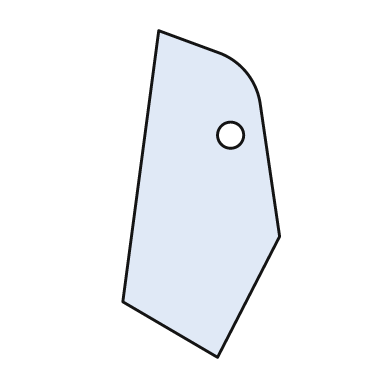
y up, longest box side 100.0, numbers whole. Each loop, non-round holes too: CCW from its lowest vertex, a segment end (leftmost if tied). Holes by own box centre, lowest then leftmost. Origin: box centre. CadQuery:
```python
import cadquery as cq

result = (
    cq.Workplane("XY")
    .moveTo(5.0, -50.0)
    .lineTo(24.0, -13.0)
    .lineTo(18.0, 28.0)
    .threePointArc((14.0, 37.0), (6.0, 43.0))
    .lineTo(-13.0, 50.0)
    .lineTo(-24.0, -33.0)
    .close()
    .moveTo(9.0, 18.0)
    .circle(4.0)
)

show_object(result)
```